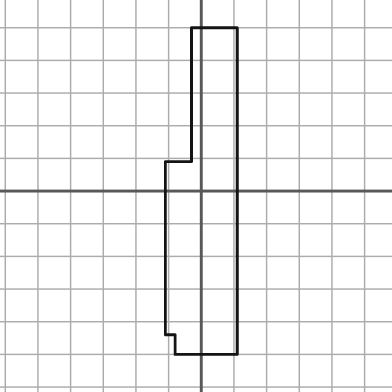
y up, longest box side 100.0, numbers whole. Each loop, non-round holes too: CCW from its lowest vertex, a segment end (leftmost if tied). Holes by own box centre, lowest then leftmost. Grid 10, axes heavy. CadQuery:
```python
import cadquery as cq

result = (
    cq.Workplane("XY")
    .moveTo(-8.0, -50.0)
    .lineTo(11.0, -50.0)
    .lineTo(11.0, 50.0)
    .lineTo(-3.0, 50.0)
    .lineTo(-3.0, 9.0)
    .lineTo(-11.0, 9.0)
    .lineTo(-11.0, -44.0)
    .lineTo(-8.0, -44.0)
    .close()
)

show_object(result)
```